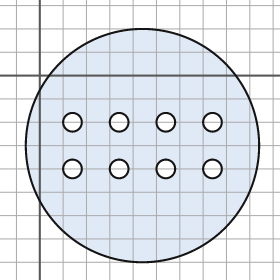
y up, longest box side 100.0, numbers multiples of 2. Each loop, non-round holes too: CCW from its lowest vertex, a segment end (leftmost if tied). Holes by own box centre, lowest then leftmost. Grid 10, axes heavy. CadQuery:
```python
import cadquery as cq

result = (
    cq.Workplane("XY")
    .moveTo(44.0, -30.0)
    .circle(50.0)
    .moveTo(14.0, -40.0)
    .circle(4.0)
    .moveTo(34.0, -40.0)
    .circle(4.0)
    .moveTo(54.0, -40.0)
    .circle(4.0)
    .moveTo(74.0, -40.0)
    .circle(4.0)
    .moveTo(14.0, -20.0)
    .circle(4.0)
    .moveTo(34.0, -20.0)
    .circle(4.0)
    .moveTo(54.0, -20.0)
    .circle(4.0)
    .moveTo(74.0, -20.0)
    .circle(4.0)
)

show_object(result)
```